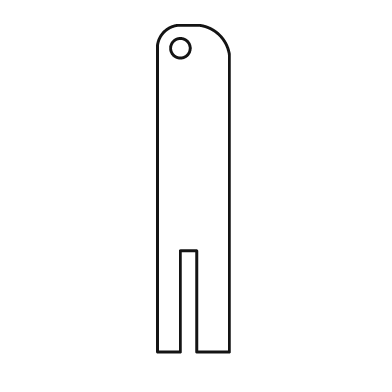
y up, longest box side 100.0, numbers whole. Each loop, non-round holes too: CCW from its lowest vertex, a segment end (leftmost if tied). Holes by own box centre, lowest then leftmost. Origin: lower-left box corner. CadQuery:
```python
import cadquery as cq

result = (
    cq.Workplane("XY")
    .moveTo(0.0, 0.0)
    .lineTo(7.0, 0.0)
    .lineTo(7.0, 31.0)
    .lineTo(12.0, 31.0)
    .lineTo(12.0, 0.0)
    .lineTo(22.0, 0.0)
    .lineTo(22.0, 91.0)
    .threePointArc((19.0, 97.0), (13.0, 100.0))
    .lineTo(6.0, 100.0)
    .threePointArc((2.0, 98.0), (0.0, 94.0))
    .close()
    .moveTo(7.0, 93.0)
    .circle(3.0)
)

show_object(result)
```